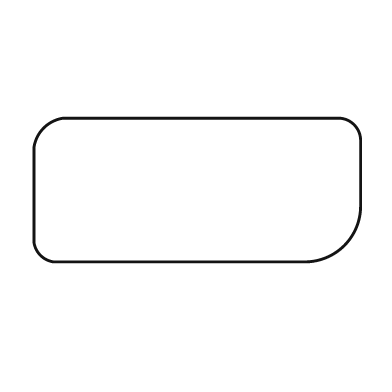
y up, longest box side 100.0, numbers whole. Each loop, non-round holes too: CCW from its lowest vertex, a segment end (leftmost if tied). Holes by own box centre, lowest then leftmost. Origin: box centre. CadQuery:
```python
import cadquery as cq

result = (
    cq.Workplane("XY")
    .moveTo(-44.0, -22.0)
    .lineTo(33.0, -22.0)
    .threePointArc((45.0, -17.0), (50.0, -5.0))
    .lineTo(50.0, 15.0)
    .threePointArc((48.0, 20.0), (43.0, 22.0))
    .lineTo(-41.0, 22.0)
    .threePointArc((-47.0, 19.0), (-50.0, 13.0))
    .lineTo(-50.0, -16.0)
    .threePointArc((-48.0, -20.0), (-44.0, -22.0))
    .close()
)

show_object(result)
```